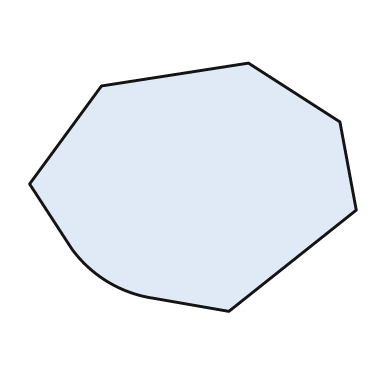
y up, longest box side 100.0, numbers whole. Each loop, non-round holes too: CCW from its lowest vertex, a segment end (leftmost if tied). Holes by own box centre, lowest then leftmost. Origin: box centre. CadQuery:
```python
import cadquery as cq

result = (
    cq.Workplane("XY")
    .moveTo(11.0, -38.0)
    .lineTo(50.0, -7.0)
    .lineTo(45.0, 20.0)
    .lineTo(17.0, 38.0)
    .lineTo(-28.0, 31.0)
    .lineTo(-50.0, 1.0)
    .lineTo(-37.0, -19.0)
    .threePointArc((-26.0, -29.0), (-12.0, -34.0))
    .close()
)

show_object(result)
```